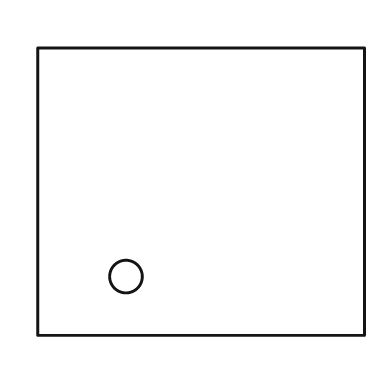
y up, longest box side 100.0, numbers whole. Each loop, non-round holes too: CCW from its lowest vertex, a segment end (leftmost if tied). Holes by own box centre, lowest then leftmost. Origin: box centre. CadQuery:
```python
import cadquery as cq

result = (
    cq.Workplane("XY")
    .moveTo(-50.0, -44.0)
    .lineTo(50.0, -44.0)
    .lineTo(50.0, 44.0)
    .lineTo(-50.0, 44.0)
    .close()
    .moveTo(-23.0, -26.0)
    .circle(5.0)
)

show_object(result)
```